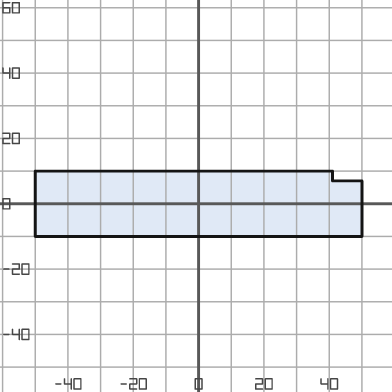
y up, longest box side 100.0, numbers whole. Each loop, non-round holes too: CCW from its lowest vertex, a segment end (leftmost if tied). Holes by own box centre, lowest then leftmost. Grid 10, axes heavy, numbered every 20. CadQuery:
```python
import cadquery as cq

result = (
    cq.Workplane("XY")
    .moveTo(-50.0, -10.0)
    .lineTo(50.0, -10.0)
    .lineTo(50.0, 7.0)
    .lineTo(41.0, 7.0)
    .lineTo(41.0, 10.0)
    .lineTo(-50.0, 10.0)
    .close()
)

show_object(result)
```